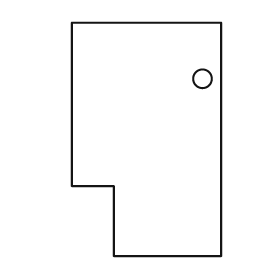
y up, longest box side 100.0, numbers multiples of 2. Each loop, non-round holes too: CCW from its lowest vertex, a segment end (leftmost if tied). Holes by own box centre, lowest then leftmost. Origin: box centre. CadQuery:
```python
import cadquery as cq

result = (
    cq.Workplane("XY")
    .moveTo(-14.0, -50.0)
    .lineTo(32.0, -50.0)
    .lineTo(32.0, 50.0)
    .lineTo(-32.0, 50.0)
    .lineTo(-32.0, -20.0)
    .lineTo(-14.0, -20.0)
    .close()
    .moveTo(24.0, 26.0)
    .circle(4.0)
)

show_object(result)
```